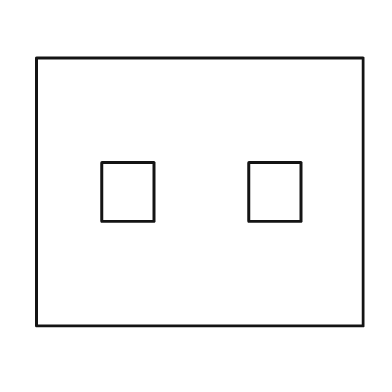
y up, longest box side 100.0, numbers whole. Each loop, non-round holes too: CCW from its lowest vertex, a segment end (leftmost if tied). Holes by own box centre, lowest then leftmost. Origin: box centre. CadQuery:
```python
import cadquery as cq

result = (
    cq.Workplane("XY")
    .moveTo(-50.0, -41.0)
    .lineTo(50.0, -41.0)
    .lineTo(50.0, 41.0)
    .lineTo(-50.0, 41.0)
    .close()
    .moveTo(-30.0, -9.0)
    .lineTo(-14.0, -9.0)
    .lineTo(-14.0, 9.0)
    .lineTo(-30.0, 9.0)
    .close()
    .moveTo(15.0, -9.0)
    .lineTo(31.0, -9.0)
    .lineTo(31.0, 9.0)
    .lineTo(15.0, 9.0)
    .close()
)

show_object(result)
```